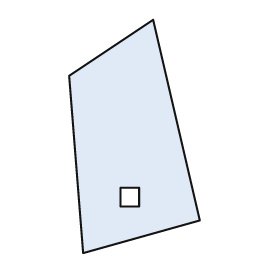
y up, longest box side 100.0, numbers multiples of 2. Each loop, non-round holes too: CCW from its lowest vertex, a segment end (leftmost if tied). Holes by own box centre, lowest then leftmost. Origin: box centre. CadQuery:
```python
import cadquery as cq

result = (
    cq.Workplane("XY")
    .moveTo(-22.0, -50.0)
    .lineTo(28.0, -36.0)
    .lineTo(8.0, 50.0)
    .lineTo(-28.0, 26.0)
    .close()
    .moveTo(-6.0, -30.0)
    .lineTo(2.0, -30.0)
    .lineTo(2.0, -22.0)
    .lineTo(-6.0, -22.0)
    .close()
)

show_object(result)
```